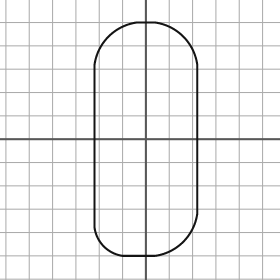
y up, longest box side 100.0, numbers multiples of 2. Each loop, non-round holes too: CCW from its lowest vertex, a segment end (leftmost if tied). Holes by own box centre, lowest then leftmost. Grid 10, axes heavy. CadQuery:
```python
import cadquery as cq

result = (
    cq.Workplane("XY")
    .moveTo(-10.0, -50.0)
    .lineTo(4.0, -50.0)
    .threePointArc((16.0, -44.0), (22.0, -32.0))
    .lineTo(22.0, 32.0)
    .threePointArc((16.0, 44.0), (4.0, 50.0))
    .lineTo(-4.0, 50.0)
    .threePointArc((-16.0, 44.0), (-22.0, 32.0))
    .lineTo(-22.0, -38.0)
    .threePointArc((-18.0, -46.0), (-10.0, -50.0))
    .close()
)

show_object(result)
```